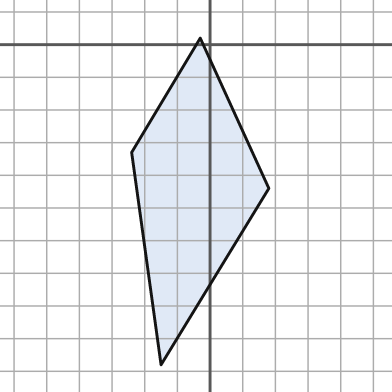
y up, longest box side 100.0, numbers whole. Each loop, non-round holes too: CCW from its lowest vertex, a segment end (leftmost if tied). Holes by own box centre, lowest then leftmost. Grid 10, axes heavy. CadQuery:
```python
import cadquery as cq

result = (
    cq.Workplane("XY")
    .moveTo(-15.0, -98.0)
    .lineTo(18.0, -44.0)
    .lineTo(-3.0, 2.0)
    .lineTo(-24.0, -33.0)
    .close()
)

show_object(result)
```